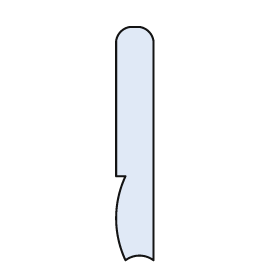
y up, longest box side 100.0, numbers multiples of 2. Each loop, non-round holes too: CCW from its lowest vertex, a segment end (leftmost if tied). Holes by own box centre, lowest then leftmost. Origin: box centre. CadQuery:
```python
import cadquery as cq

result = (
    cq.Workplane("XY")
    .moveTo(-4.0, -50.0)
    .threePointArc((2.0, -48.0), (8.0, -50.0))
    .lineTo(8.0, 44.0)
    .threePointArc((6.0, 48.0), (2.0, 50.0))
    .lineTo(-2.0, 50.0)
    .threePointArc((-6.0, 48.0), (-8.0, 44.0))
    .lineTo(-8.0, -14.0)
    .lineTo(-4.0, -14.0)
    .threePointArc((-8.0, -32.0), (-4.0, -50.0))
    .close()
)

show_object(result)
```